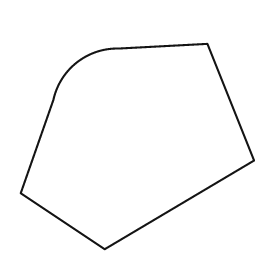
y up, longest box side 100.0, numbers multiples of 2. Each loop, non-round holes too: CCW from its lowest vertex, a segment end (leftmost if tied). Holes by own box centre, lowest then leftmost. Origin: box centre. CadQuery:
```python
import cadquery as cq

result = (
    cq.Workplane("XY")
    .moveTo(-14.0, -44.0)
    .lineTo(50.0, -6.0)
    .lineTo(30.0, 44.0)
    .lineTo(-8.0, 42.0)
    .threePointArc((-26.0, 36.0), (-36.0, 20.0))
    .lineTo(-50.0, -20.0)
    .close()
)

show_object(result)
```